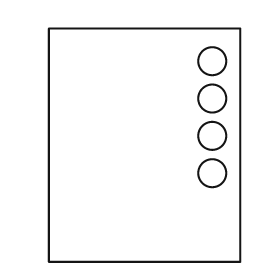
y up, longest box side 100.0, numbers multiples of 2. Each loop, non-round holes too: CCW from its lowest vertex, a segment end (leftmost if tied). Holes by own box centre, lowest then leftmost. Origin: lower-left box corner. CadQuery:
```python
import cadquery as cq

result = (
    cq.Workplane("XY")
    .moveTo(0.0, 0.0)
    .lineTo(82.0, 0.0)
    .lineTo(82.0, 100.0)
    .lineTo(0.0, 100.0)
    .close()
    .moveTo(70.0, 38.0)
    .circle(6.0)
    .moveTo(70.0, 54.0)
    .circle(6.0)
    .moveTo(70.0, 70.0)
    .circle(6.0)
    .moveTo(70.0, 86.0)
    .circle(6.0)
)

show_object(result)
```